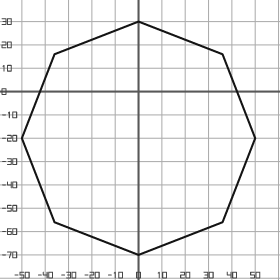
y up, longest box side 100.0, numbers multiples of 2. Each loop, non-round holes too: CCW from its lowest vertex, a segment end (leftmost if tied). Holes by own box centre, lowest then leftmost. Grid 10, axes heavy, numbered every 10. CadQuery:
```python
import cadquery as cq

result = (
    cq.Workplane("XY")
    .moveTo(0.0, -70.0)
    .lineTo(36.0, -56.0)
    .lineTo(50.0, -20.0)
    .lineTo(36.0, 16.0)
    .lineTo(0.0, 30.0)
    .lineTo(-36.0, 16.0)
    .lineTo(-50.0, -20.0)
    .lineTo(-36.0, -56.0)
    .close()
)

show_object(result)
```